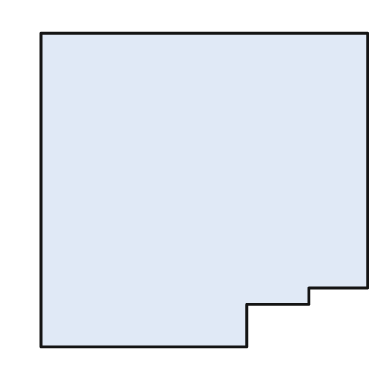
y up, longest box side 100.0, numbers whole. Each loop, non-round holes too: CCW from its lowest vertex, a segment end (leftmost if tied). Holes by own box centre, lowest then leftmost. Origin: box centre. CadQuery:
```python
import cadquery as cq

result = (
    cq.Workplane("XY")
    .moveTo(-50.0, -48.0)
    .lineTo(13.0, -48.0)
    .lineTo(13.0, -35.0)
    .lineTo(32.0, -35.0)
    .lineTo(32.0, -30.0)
    .lineTo(50.0, -30.0)
    .lineTo(50.0, 48.0)
    .lineTo(-50.0, 48.0)
    .close()
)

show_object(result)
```